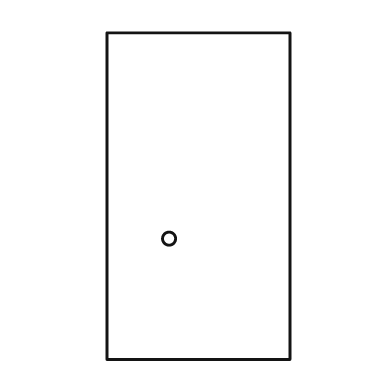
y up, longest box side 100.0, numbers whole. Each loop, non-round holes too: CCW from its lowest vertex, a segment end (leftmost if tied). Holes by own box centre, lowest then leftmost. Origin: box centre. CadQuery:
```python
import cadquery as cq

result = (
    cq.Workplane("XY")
    .moveTo(-28.0, -50.0)
    .lineTo(28.0, -50.0)
    .lineTo(28.0, 50.0)
    .lineTo(-28.0, 50.0)
    .close()
    .moveTo(-9.0, -13.0)
    .circle(2.0)
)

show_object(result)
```